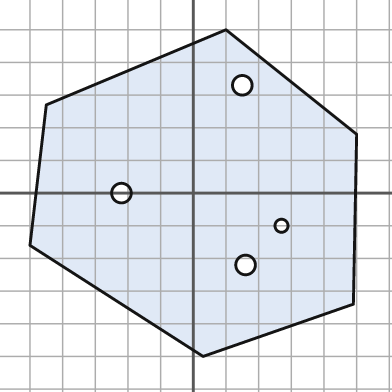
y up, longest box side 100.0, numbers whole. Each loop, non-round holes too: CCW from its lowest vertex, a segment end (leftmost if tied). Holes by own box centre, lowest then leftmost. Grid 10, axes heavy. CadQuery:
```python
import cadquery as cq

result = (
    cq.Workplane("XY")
    .moveTo(3.0, -50.0)
    .lineTo(49.0, -34.0)
    .lineTo(50.0, 18.0)
    .lineTo(10.0, 50.0)
    .lineTo(-45.0, 27.0)
    .lineTo(-50.0, -16.0)
    .close()
    .moveTo(16.0, -22.0)
    .circle(3.0)
    .moveTo(27.0, -10.0)
    .circle(2.0)
    .moveTo(-22.0, 0.0)
    .circle(3.0)
    .moveTo(15.0, 33.0)
    .circle(3.0)
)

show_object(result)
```